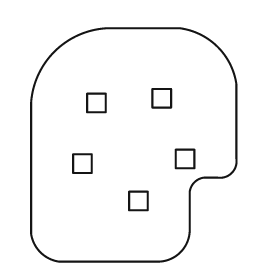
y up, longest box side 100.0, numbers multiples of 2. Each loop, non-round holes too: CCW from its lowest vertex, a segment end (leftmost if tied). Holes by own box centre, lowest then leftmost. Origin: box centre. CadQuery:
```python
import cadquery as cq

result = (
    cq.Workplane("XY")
    .moveTo(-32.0, -50.0)
    .lineTo(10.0, -50.0)
    .threePointArc((20.0, -46.0), (24.0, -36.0))
    .lineTo(24.0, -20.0)
    .threePointArc((26.0, -16.0), (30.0, -14.0))
    .lineTo(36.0, -14.0)
    .threePointArc((42.0, -12.0), (44.0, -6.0))
    .lineTo(44.0, 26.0)
    .threePointArc((36.0, 42.0), (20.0, 50.0))
    .lineTo(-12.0, 50.0)
    .threePointArc((-34.0, 40.0), (-44.0, 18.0))
    .lineTo(-44.0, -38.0)
    .threePointArc((-40.0, -46.0), (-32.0, -50.0))
    .close()
    .moveTo(-2.0, -28.0)
    .lineTo(6.0, -28.0)
    .lineTo(6.0, -20.0)
    .lineTo(-2.0, -20.0)
    .close()
    .moveTo(-26.0, -12.0)
    .lineTo(-18.0, -12.0)
    .lineTo(-18.0, -4.0)
    .lineTo(-26.0, -4.0)
    .close()
    .moveTo(18.0, -10.0)
    .lineTo(26.0, -10.0)
    .lineTo(26.0, -2.0)
    .lineTo(18.0, -2.0)
    .close()
    .moveTo(-20.0, 14.0)
    .lineTo(-12.0, 14.0)
    .lineTo(-12.0, 22.0)
    .lineTo(-20.0, 22.0)
    .close()
    .moveTo(8.0, 16.0)
    .lineTo(16.0, 16.0)
    .lineTo(16.0, 24.0)
    .lineTo(8.0, 24.0)
    .close()
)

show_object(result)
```